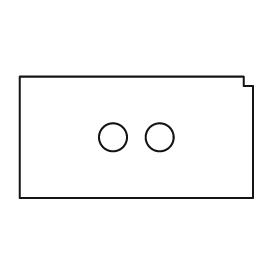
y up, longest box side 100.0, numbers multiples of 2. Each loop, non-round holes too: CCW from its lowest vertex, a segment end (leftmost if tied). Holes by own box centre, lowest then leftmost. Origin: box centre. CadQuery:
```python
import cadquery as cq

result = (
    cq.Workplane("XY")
    .moveTo(-50.0, -26.0)
    .lineTo(50.0, -26.0)
    .lineTo(50.0, 22.0)
    .lineTo(46.0, 22.0)
    .lineTo(46.0, 26.0)
    .lineTo(-50.0, 26.0)
    .close()
    .moveTo(-10.0, 0.0)
    .circle(6.0)
    .moveTo(10.0, 0.0)
    .circle(6.0)
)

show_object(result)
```